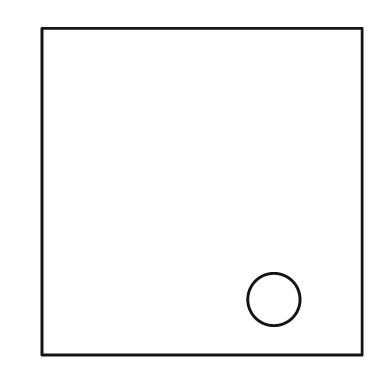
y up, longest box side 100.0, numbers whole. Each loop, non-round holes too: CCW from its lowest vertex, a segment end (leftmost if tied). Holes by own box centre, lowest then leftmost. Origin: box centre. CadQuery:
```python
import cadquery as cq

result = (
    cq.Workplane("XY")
    .moveTo(-49.0, -50.0)
    .lineTo(49.0, -50.0)
    .lineTo(49.0, 50.0)
    .lineTo(-49.0, 50.0)
    .close()
    .moveTo(22.0, -33.0)
    .circle(8.0)
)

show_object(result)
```